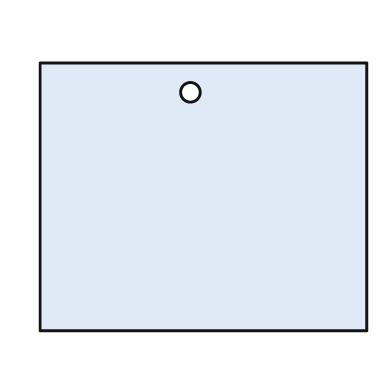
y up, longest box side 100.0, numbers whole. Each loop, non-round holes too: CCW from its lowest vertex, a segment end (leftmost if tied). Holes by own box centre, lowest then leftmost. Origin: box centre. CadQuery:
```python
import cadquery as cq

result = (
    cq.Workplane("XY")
    .moveTo(-50.0, -41.0)
    .lineTo(50.0, -41.0)
    .lineTo(50.0, 41.0)
    .lineTo(-50.0, 41.0)
    .close()
    .moveTo(-4.0, 32.0)
    .circle(3.0)
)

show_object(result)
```